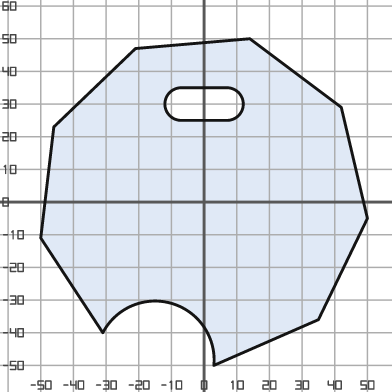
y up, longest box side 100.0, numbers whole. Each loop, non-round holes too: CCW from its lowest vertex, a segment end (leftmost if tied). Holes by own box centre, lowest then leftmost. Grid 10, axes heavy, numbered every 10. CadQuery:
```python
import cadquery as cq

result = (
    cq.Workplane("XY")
    .moveTo(3.0, -50.0)
    .lineTo(35.0, -36.0)
    .lineTo(50.0, -5.0)
    .lineTo(42.0, 29.0)
    .lineTo(14.0, 50.0)
    .lineTo(-21.0, 47.0)
    .lineTo(-46.0, 23.0)
    .lineTo(-50.0, -11.0)
    .lineTo(-31.0, -40.0)
    .threePointArc((-10.0, -31.0), (3.0, -50.0))
    .close()
    .moveTo(-7.0, 25.0)
    .lineTo(7.0, 25.0)
    .threePointArc((12.0, 30.0), (7.0, 35.0))
    .lineTo(-7.0, 35.0)
    .threePointArc((-12.0, 30.0), (-7.0, 25.0))
    .close()
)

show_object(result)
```